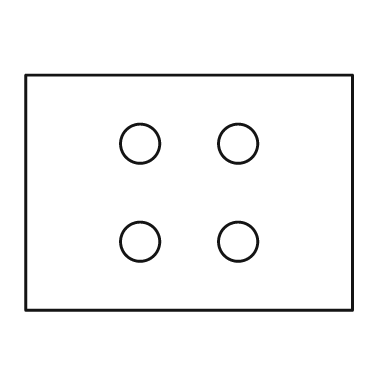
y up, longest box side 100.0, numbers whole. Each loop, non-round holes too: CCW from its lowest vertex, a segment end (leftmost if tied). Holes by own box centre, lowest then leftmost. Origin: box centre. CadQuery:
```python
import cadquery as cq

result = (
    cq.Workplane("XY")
    .moveTo(-50.0, -36.0)
    .lineTo(50.0, -36.0)
    .lineTo(50.0, 36.0)
    .lineTo(-50.0, 36.0)
    .close()
    .moveTo(-15.0, -15.0)
    .circle(6.0)
    .moveTo(15.0, -15.0)
    .circle(6.0)
    .moveTo(-15.0, 15.0)
    .circle(6.0)
    .moveTo(15.0, 15.0)
    .circle(6.0)
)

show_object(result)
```